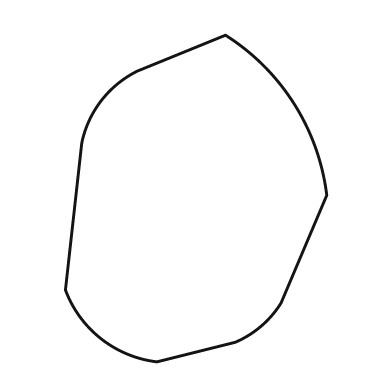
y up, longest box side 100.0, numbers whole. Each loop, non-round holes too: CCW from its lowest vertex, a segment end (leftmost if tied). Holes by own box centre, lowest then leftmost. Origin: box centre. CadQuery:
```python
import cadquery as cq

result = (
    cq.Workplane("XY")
    .moveTo(-12.0, -50.0)
    .lineTo(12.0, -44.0)
    .threePointArc((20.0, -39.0), (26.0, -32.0))
    .lineTo(40.0, 1.0)
    .threePointArc((30.0, 29.0), (9.0, 50.0))
    .lineTo(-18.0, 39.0)
    .threePointArc((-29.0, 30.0), (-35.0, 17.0))
    .lineTo(-40.0, -28.0)
    .threePointArc((-29.0, -43.0), (-12.0, -50.0))
    .close()
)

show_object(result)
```